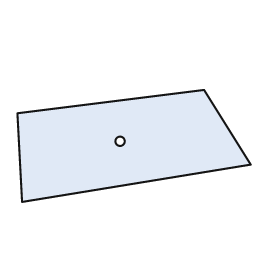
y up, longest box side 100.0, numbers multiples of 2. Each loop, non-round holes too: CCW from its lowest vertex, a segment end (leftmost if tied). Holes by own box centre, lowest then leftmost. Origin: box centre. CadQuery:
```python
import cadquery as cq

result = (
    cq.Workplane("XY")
    .moveTo(-48.0, -24.0)
    .lineTo(50.0, -8.0)
    .lineTo(30.0, 24.0)
    .lineTo(-50.0, 14.0)
    .close()
    .moveTo(-6.0, 2.0)
    .circle(2.0)
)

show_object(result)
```